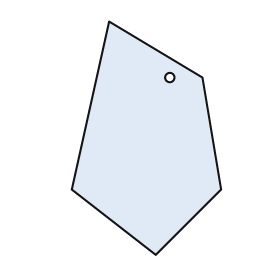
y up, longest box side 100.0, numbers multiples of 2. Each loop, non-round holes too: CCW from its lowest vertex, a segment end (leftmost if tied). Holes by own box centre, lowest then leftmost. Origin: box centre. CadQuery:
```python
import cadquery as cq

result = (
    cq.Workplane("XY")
    .moveTo(4.0, -50.0)
    .lineTo(32.0, -22.0)
    .lineTo(24.0, 26.0)
    .lineTo(-16.0, 50.0)
    .lineTo(-32.0, -22.0)
    .close()
    .moveTo(10.0, 26.0)
    .circle(2.0)
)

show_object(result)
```